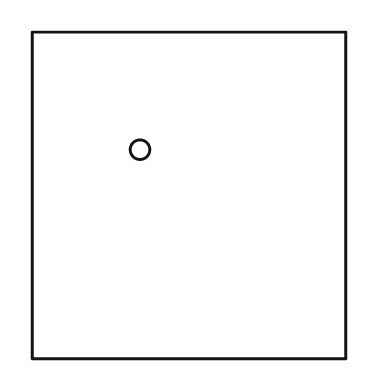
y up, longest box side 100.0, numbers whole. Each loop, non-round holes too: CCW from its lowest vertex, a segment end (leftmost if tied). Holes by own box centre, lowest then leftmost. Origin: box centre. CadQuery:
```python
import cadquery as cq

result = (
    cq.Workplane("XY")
    .moveTo(-48.0, -50.0)
    .lineTo(48.0, -50.0)
    .lineTo(48.0, 50.0)
    .lineTo(-48.0, 50.0)
    .close()
    .moveTo(-15.0, 14.0)
    .circle(3.0)
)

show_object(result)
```